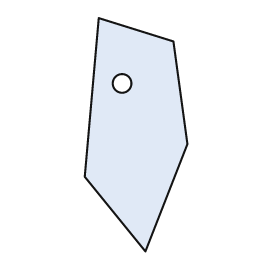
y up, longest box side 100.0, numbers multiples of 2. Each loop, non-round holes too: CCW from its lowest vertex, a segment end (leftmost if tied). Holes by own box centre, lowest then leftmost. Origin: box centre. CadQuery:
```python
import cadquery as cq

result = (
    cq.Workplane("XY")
    .moveTo(4.0, -50.0)
    .lineTo(22.0, -4.0)
    .lineTo(16.0, 40.0)
    .lineTo(-16.0, 50.0)
    .lineTo(-22.0, -18.0)
    .close()
    .moveTo(-6.0, 22.0)
    .circle(4.0)
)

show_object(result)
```